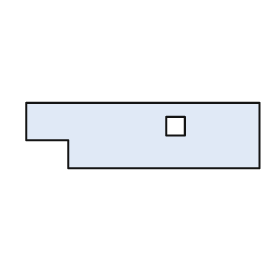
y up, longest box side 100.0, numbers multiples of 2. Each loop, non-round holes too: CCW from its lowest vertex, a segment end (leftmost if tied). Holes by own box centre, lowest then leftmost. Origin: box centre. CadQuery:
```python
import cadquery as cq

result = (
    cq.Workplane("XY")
    .moveTo(-32.0, -14.0)
    .lineTo(50.0, -14.0)
    .lineTo(50.0, 14.0)
    .lineTo(-50.0, 14.0)
    .lineTo(-50.0, -2.0)
    .lineTo(-32.0, -2.0)
    .close()
    .moveTo(10.0, 0.0)
    .lineTo(18.0, 0.0)
    .lineTo(18.0, 8.0)
    .lineTo(10.0, 8.0)
    .close()
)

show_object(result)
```